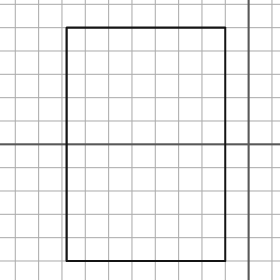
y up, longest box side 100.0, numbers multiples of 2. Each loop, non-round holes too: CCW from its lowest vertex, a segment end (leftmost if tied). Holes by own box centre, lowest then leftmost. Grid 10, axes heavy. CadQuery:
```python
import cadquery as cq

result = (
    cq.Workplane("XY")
    .moveTo(-78.0, -50.0)
    .lineTo(-10.0, -50.0)
    .lineTo(-10.0, 50.0)
    .lineTo(-78.0, 50.0)
    .close()
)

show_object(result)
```